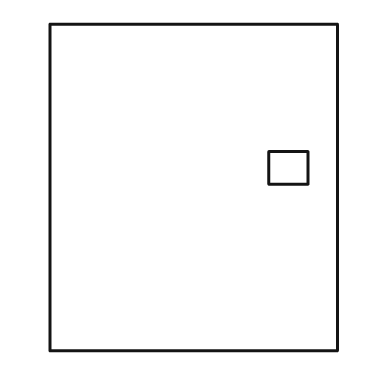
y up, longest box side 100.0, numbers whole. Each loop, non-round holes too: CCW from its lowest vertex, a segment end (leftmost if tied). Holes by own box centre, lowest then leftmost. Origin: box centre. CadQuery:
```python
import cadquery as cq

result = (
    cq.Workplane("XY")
    .moveTo(-44.0, -50.0)
    .lineTo(44.0, -50.0)
    .lineTo(44.0, 50.0)
    .lineTo(-44.0, 50.0)
    .close()
    .moveTo(23.0, 1.0)
    .lineTo(35.0, 1.0)
    .lineTo(35.0, 11.0)
    .lineTo(23.0, 11.0)
    .close()
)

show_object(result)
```